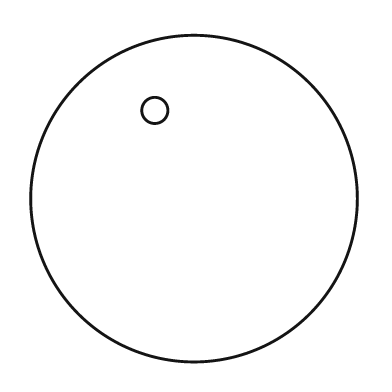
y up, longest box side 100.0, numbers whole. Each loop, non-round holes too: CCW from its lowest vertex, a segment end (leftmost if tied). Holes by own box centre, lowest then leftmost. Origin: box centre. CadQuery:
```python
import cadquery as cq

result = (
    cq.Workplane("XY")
    .moveTo(0.0, 0.0)
    .circle(50.0)
    .moveTo(-12.0, 27.0)
    .circle(4.0)
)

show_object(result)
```